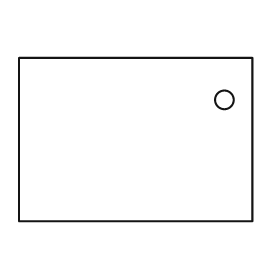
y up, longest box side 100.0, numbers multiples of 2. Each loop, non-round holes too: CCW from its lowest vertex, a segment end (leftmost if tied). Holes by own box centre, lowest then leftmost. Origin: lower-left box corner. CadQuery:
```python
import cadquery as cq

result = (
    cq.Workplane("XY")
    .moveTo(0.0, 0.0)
    .lineTo(100.0, 0.0)
    .lineTo(100.0, 70.0)
    .lineTo(0.0, 70.0)
    .close()
    .moveTo(88.0, 52.0)
    .circle(4.0)
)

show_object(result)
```